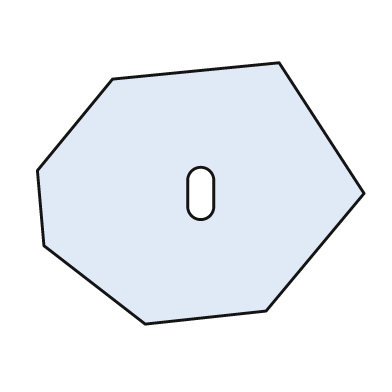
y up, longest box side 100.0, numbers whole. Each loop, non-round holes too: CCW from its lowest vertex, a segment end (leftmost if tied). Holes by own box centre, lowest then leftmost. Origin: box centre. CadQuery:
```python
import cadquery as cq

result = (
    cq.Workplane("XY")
    .moveTo(-17.0, -40.0)
    .lineTo(20.0, -36.0)
    .lineTo(50.0, 0.0)
    .lineTo(24.0, 40.0)
    .lineTo(-27.0, 35.0)
    .lineTo(-50.0, 7.0)
    .lineTo(-48.0, -16.0)
    .close()
    .moveTo(-4.0, -4.0)
    .threePointArc((0.0, -8.0), (4.0, -4.0))
    .lineTo(4.0, 4.0)
    .threePointArc((0.0, 8.0), (-4.0, 4.0))
    .close()
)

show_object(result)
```